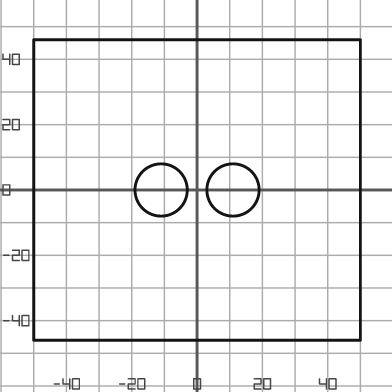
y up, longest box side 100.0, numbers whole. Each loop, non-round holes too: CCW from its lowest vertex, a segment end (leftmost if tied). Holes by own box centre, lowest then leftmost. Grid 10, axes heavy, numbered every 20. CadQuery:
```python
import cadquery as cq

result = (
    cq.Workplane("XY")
    .moveTo(-50.0, -46.0)
    .lineTo(50.0, -46.0)
    .lineTo(50.0, 46.0)
    .lineTo(-50.0, 46.0)
    .close()
    .moveTo(-11.0, 0.0)
    .circle(8.0)
    .moveTo(11.0, 0.0)
    .circle(8.0)
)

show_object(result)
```